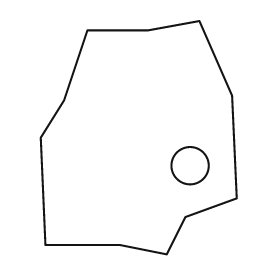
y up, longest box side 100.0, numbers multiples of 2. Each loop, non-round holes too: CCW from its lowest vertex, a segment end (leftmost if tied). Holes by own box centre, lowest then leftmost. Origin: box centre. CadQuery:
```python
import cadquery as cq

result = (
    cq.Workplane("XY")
    .moveTo(12.0, -50.0)
    .lineTo(20.0, -34.0)
    .lineTo(42.0, -26.0)
    .lineTo(40.0, 18.0)
    .lineTo(26.0, 50.0)
    .lineTo(4.0, 46.0)
    .lineTo(-22.0, 46.0)
    .lineTo(-32.0, 16.0)
    .lineTo(-42.0, 0.0)
    .lineTo(-40.0, -46.0)
    .lineTo(-8.0, -46.0)
    .close()
    .moveTo(22.0, -12.0)
    .circle(8.0)
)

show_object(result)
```